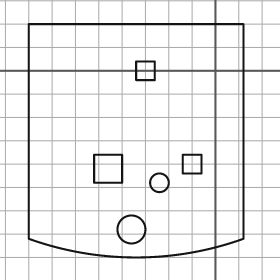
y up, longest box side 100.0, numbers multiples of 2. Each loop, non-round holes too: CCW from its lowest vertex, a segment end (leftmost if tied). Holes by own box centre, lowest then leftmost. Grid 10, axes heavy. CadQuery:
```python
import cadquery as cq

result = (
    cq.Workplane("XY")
    .moveTo(-80.0, -72.0)
    .threePointArc((-34.0, -80.0), (12.0, -72.0))
    .lineTo(12.0, 20.0)
    .lineTo(-80.0, 20.0)
    .close()
    .moveTo(-36.0, -68.0)
    .circle(6.0)
    .moveTo(-24.0, -48.0)
    .circle(4.0)
    .moveTo(-52.0, -48.0)
    .lineTo(-40.0, -48.0)
    .lineTo(-40.0, -36.0)
    .lineTo(-52.0, -36.0)
    .close()
    .moveTo(-14.0, -44.0)
    .lineTo(-6.0, -44.0)
    .lineTo(-6.0, -36.0)
    .lineTo(-14.0, -36.0)
    .close()
    .moveTo(-34.0, -4.0)
    .lineTo(-26.0, -4.0)
    .lineTo(-26.0, 4.0)
    .lineTo(-34.0, 4.0)
    .close()
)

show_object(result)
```